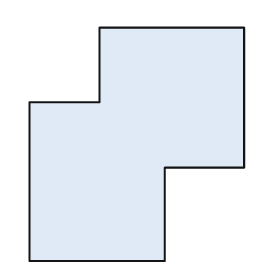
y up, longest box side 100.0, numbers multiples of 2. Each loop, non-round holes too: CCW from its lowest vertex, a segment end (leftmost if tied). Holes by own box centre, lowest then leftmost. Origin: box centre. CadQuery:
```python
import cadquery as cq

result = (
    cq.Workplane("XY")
    .moveTo(-46.0, -50.0)
    .lineTo(12.0, -50.0)
    .lineTo(12.0, -10.0)
    .lineTo(46.0, -10.0)
    .lineTo(46.0, 50.0)
    .lineTo(-16.0, 50.0)
    .lineTo(-16.0, 18.0)
    .lineTo(-46.0, 18.0)
    .close()
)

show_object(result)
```